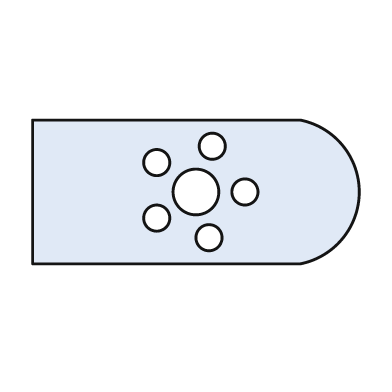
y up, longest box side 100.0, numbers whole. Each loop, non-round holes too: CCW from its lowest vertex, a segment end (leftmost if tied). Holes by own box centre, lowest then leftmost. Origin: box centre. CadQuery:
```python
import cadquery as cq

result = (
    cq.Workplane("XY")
    .moveTo(-50.0, -22.0)
    .lineTo(32.0, -22.0)
    .threePointArc((50.0, 0.0), (32.0, 22.0))
    .lineTo(-50.0, 22.0)
    .close()
    .moveTo(4.0, -14.0)
    .circle(4.0)
    .moveTo(-12.0, -8.0)
    .circle(4.0)
    .moveTo(0.0, 0.0)
    .circle(7.0)
    .moveTo(15.0, 0.0)
    .circle(4.0)
    .moveTo(-12.0, 9.0)
    .circle(4.0)
    .moveTo(5.0, 14.0)
    .circle(4.0)
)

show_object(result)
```